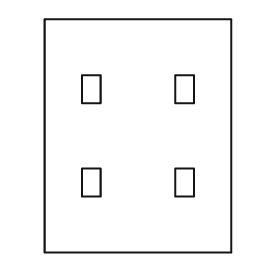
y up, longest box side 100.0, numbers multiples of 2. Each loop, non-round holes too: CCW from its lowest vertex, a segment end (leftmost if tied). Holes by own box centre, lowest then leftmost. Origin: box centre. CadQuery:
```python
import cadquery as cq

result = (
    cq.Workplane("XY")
    .moveTo(-40.0, -50.0)
    .lineTo(40.0, -50.0)
    .lineTo(40.0, 50.0)
    .lineTo(-40.0, 50.0)
    .close()
    .moveTo(-24.0, -26.0)
    .lineTo(-16.0, -26.0)
    .lineTo(-16.0, -14.0)
    .lineTo(-24.0, -14.0)
    .close()
    .moveTo(16.0, -26.0)
    .lineTo(24.0, -26.0)
    .lineTo(24.0, -14.0)
    .lineTo(16.0, -14.0)
    .close()
    .moveTo(-24.0, 14.0)
    .lineTo(-16.0, 14.0)
    .lineTo(-16.0, 26.0)
    .lineTo(-24.0, 26.0)
    .close()
    .moveTo(16.0, 14.0)
    .lineTo(24.0, 14.0)
    .lineTo(24.0, 26.0)
    .lineTo(16.0, 26.0)
    .close()
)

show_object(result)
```